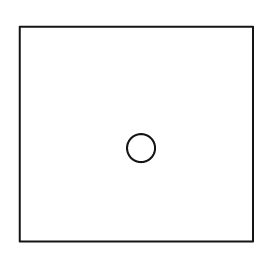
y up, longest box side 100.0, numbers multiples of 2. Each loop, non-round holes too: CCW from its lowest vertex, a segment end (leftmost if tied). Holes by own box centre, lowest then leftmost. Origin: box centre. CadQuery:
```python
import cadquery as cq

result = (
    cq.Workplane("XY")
    .moveTo(-50.0, -46.0)
    .lineTo(50.0, -46.0)
    .lineTo(50.0, 46.0)
    .lineTo(-50.0, 46.0)
    .close()
    .moveTo(2.0, -6.0)
    .circle(6.0)
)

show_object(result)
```